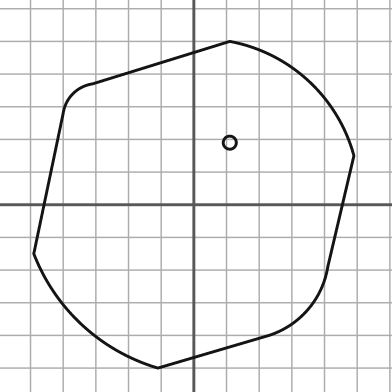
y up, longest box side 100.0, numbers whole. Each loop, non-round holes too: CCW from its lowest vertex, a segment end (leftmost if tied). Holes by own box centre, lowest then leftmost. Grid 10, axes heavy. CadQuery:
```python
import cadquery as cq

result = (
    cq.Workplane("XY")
    .moveTo(-11.0, -50.0)
    .lineTo(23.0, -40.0)
    .threePointArc((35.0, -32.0), (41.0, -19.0))
    .lineTo(49.0, 15.0)
    .threePointArc((35.0, 38.0), (11.0, 50.0))
    .lineTo(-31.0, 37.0)
    .threePointArc((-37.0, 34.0), (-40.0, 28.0))
    .lineTo(-49.0, -15.0)
    .threePointArc((-34.0, -37.0), (-11.0, -50.0))
    .close()
    .moveTo(11.0, 19.0)
    .circle(2.0)
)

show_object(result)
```